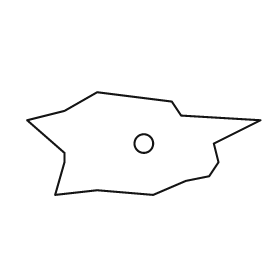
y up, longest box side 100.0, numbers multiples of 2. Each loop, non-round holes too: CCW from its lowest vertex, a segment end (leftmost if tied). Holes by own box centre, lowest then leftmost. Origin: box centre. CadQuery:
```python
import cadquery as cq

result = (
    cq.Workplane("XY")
    .moveTo(-38.0, -22.0)
    .lineTo(-20.0, -20.0)
    .lineTo(4.0, -22.0)
    .lineTo(18.0, -16.0)
    .lineTo(28.0, -14.0)
    .lineTo(32.0, -8.0)
    .lineTo(30.0, 0.0)
    .lineTo(50.0, 10.0)
    .lineTo(16.0, 12.0)
    .lineTo(12.0, 18.0)
    .lineTo(-20.0, 22.0)
    .lineTo(-34.0, 14.0)
    .lineTo(-50.0, 10.0)
    .lineTo(-34.0, -4.0)
    .lineTo(-34.0, -8.0)
    .close()
    .moveTo(0.0, 0.0)
    .circle(4.0)
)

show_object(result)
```